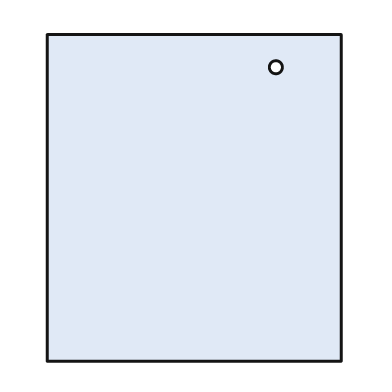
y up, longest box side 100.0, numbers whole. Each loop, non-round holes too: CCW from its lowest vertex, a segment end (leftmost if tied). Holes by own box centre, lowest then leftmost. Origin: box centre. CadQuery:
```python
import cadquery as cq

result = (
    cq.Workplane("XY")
    .moveTo(-45.0, -50.0)
    .lineTo(45.0, -50.0)
    .lineTo(45.0, 50.0)
    .lineTo(-45.0, 50.0)
    .close()
    .moveTo(25.0, 40.0)
    .circle(2.0)
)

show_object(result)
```